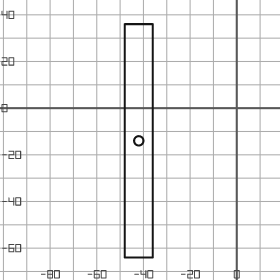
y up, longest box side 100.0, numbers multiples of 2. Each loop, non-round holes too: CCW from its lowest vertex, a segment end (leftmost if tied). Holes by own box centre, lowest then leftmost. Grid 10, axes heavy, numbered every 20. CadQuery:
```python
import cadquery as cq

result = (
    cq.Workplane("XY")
    .moveTo(-48.0, -64.0)
    .lineTo(-36.0, -64.0)
    .lineTo(-36.0, 36.0)
    .lineTo(-48.0, 36.0)
    .close()
    .moveTo(-42.0, -14.0)
    .circle(2.0)
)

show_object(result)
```